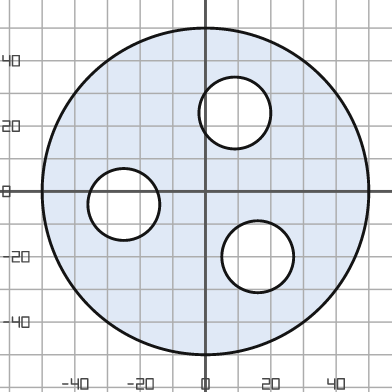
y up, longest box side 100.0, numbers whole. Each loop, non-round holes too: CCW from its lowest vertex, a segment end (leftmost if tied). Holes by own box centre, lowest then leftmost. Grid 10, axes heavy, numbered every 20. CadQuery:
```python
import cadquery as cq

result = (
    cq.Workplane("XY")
    .moveTo(0.0, 0.0)
    .circle(50.0)
    .moveTo(16.0, -20.0)
    .circle(11.0)
    .moveTo(-25.0, -4.0)
    .circle(11.0)
    .moveTo(9.0, 24.0)
    .circle(11.0)
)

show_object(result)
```